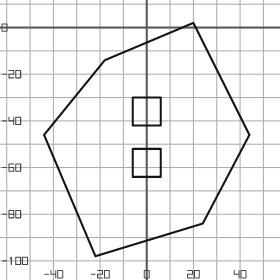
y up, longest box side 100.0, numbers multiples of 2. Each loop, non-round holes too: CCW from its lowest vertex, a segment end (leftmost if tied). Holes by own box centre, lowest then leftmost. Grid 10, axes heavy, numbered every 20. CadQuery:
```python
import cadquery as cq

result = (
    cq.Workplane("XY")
    .moveTo(-22.0, -98.0)
    .lineTo(24.0, -84.0)
    .lineTo(44.0, -46.0)
    .lineTo(20.0, 2.0)
    .lineTo(-18.0, -14.0)
    .lineTo(-44.0, -46.0)
    .close()
    .moveTo(-6.0, -64.0)
    .lineTo(6.0, -64.0)
    .lineTo(6.0, -52.0)
    .lineTo(-6.0, -52.0)
    .close()
    .moveTo(-6.0, -42.0)
    .lineTo(6.0, -42.0)
    .lineTo(6.0, -30.0)
    .lineTo(-6.0, -30.0)
    .close()
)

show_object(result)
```